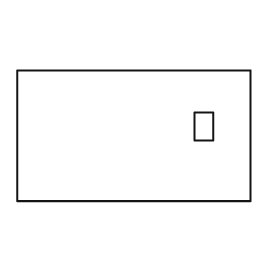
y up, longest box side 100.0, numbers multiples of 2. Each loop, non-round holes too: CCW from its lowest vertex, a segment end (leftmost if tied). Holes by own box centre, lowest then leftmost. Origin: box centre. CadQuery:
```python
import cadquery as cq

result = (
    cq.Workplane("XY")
    .moveTo(-50.0, -28.0)
    .lineTo(50.0, -28.0)
    .lineTo(50.0, 28.0)
    .lineTo(-50.0, 28.0)
    .close()
    .moveTo(26.0, -2.0)
    .lineTo(34.0, -2.0)
    .lineTo(34.0, 10.0)
    .lineTo(26.0, 10.0)
    .close()
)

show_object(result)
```